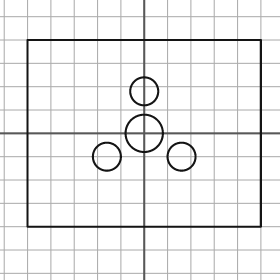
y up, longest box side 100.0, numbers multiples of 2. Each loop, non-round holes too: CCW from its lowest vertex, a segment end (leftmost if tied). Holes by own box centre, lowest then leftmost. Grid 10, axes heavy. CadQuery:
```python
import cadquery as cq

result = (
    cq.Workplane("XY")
    .moveTo(-50.0, -40.0)
    .lineTo(50.0, -40.0)
    .lineTo(50.0, 40.0)
    .lineTo(-50.0, 40.0)
    .close()
    .moveTo(-16.0, -10.0)
    .circle(6.0)
    .moveTo(16.0, -10.0)
    .circle(6.0)
    .moveTo(0.0, 0.0)
    .circle(8.0)
    .moveTo(0.0, 18.0)
    .circle(6.0)
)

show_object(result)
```